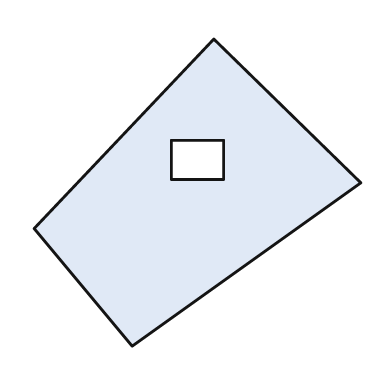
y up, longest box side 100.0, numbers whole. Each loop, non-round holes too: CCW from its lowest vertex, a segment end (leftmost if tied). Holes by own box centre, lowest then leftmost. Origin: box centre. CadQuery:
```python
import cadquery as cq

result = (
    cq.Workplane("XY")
    .moveTo(-20.0, -47.0)
    .lineTo(50.0, 3.0)
    .lineTo(5.0, 47.0)
    .lineTo(-50.0, -11.0)
    .close()
    .moveTo(-8.0, 4.0)
    .lineTo(8.0, 4.0)
    .lineTo(8.0, 16.0)
    .lineTo(-8.0, 16.0)
    .close()
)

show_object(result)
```